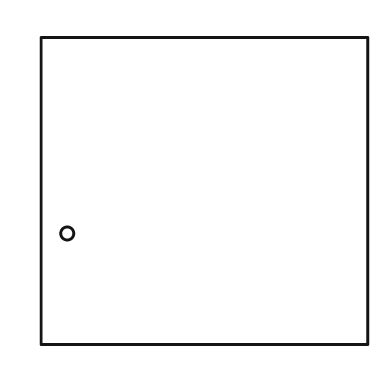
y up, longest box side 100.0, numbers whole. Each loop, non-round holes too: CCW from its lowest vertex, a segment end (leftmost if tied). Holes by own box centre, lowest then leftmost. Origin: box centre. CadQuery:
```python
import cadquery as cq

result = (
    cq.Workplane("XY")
    .moveTo(-50.0, -47.0)
    .lineTo(50.0, -47.0)
    .lineTo(50.0, 47.0)
    .lineTo(-50.0, 47.0)
    .close()
    .moveTo(-42.0, -13.0)
    .circle(2.0)
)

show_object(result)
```